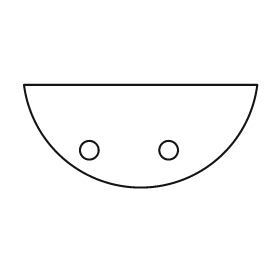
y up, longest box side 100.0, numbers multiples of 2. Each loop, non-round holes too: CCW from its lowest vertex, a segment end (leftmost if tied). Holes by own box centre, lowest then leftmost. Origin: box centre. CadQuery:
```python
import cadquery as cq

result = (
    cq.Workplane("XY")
    .moveTo(-50.0, 22.0)
    .threePointArc((0.0, -22.0), (50.0, 22.0))
    .close()
    .moveTo(-22.0, -6.0)
    .circle(4.0)
    .moveTo(12.0, -6.0)
    .circle(4.0)
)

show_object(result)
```